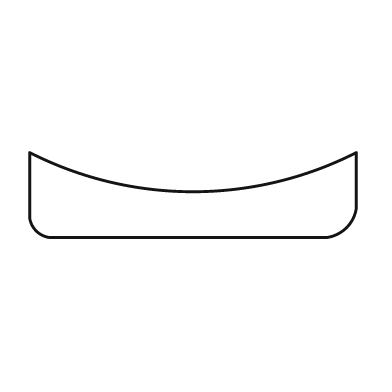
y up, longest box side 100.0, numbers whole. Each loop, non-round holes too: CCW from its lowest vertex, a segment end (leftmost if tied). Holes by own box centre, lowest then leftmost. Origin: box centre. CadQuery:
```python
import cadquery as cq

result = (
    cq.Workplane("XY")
    .moveTo(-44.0, -13.0)
    .lineTo(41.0, -13.0)
    .threePointArc((47.0, -10.0), (50.0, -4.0))
    .lineTo(50.0, 13.0)
    .threePointArc((0.0, 1.0), (-50.0, 13.0))
    .lineTo(-50.0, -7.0)
    .threePointArc((-48.0, -11.0), (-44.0, -13.0))
    .close()
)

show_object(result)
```